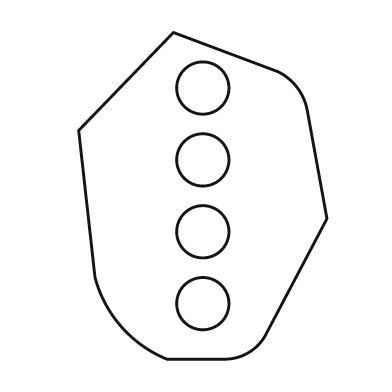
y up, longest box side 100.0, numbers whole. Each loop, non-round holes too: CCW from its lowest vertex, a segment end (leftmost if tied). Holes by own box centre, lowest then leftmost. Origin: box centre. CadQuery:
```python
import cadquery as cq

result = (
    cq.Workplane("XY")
    .moveTo(-11.0, -50.0)
    .lineTo(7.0, -50.0)
    .threePointArc((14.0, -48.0), (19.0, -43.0))
    .lineTo(38.0, -7.0)
    .lineTo(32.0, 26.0)
    .threePointArc((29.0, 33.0), (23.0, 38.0))
    .lineTo(-9.0, 50.0)
    .lineTo(-38.0, 20.0)
    .lineTo(-33.0, -25.0)
    .threePointArc((-25.0, -40.0), (-11.0, -50.0))
    .close()
    .moveTo(0.0, -33.0)
    .circle(8.0)
    .moveTo(0.0, -11.0)
    .circle(8.0)
    .moveTo(0.0, 11.0)
    .circle(8.0)
    .moveTo(0.0, 33.0)
    .circle(8.0)
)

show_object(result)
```